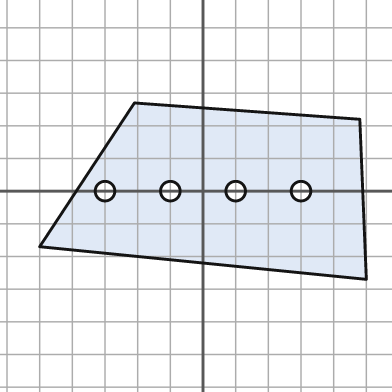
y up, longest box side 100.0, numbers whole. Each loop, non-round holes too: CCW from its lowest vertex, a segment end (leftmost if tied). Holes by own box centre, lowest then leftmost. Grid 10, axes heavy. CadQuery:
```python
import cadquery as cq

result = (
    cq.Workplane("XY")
    .moveTo(50.0, -27.0)
    .lineTo(48.0, 22.0)
    .lineTo(-21.0, 27.0)
    .lineTo(-50.0, -17.0)
    .close()
    .moveTo(-30.0, 0.0)
    .circle(3.0)
    .moveTo(-10.0, 0.0)
    .circle(3.0)
    .moveTo(10.0, 0.0)
    .circle(3.0)
    .moveTo(30.0, 0.0)
    .circle(3.0)
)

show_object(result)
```